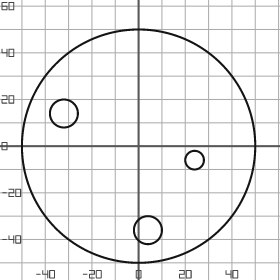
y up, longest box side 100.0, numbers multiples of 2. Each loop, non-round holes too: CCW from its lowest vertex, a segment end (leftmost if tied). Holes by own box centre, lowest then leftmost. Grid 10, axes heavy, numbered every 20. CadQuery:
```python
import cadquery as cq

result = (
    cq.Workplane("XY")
    .moveTo(0.0, 0.0)
    .circle(50.0)
    .moveTo(4.0, -36.0)
    .circle(6.0)
    .moveTo(24.0, -6.0)
    .circle(4.0)
    .moveTo(-32.0, 14.0)
    .circle(6.0)
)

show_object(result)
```